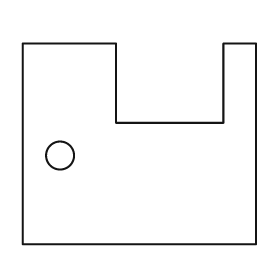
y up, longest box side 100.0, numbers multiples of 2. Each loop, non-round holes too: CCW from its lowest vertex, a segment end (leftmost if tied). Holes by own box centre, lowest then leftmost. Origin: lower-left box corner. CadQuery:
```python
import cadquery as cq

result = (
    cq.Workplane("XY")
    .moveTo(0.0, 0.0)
    .lineTo(100.0, 0.0)
    .lineTo(100.0, 86.0)
    .lineTo(86.0, 86.0)
    .lineTo(86.0, 52.0)
    .lineTo(40.0, 52.0)
    .lineTo(40.0, 86.0)
    .lineTo(0.0, 86.0)
    .close()
    .moveTo(16.0, 38.0)
    .circle(6.0)
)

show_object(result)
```